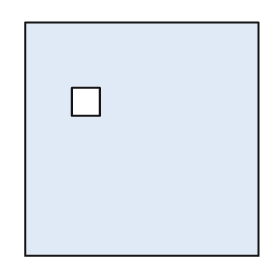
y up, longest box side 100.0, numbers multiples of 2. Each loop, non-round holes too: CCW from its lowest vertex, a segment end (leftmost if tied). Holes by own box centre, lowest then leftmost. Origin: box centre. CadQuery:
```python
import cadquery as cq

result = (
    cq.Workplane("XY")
    .moveTo(-50.0, -50.0)
    .lineTo(50.0, -50.0)
    .lineTo(50.0, 50.0)
    .lineTo(-50.0, 50.0)
    .close()
    .moveTo(-30.0, 10.0)
    .lineTo(-18.0, 10.0)
    .lineTo(-18.0, 22.0)
    .lineTo(-30.0, 22.0)
    .close()
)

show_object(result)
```